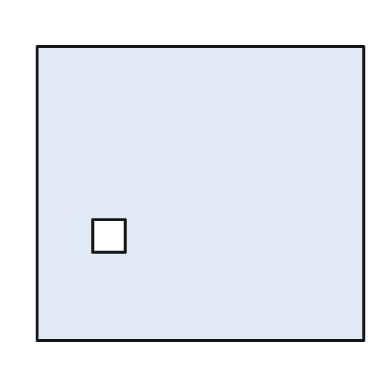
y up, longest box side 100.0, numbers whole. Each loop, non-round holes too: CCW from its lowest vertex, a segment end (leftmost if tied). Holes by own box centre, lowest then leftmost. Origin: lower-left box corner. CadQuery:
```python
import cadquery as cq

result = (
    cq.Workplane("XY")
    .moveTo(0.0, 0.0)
    .lineTo(100.0, 0.0)
    .lineTo(100.0, 90.0)
    .lineTo(0.0, 90.0)
    .close()
    .moveTo(17.0, 27.0)
    .lineTo(27.0, 27.0)
    .lineTo(27.0, 37.0)
    .lineTo(17.0, 37.0)
    .close()
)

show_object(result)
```